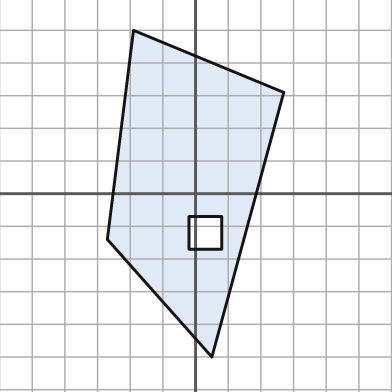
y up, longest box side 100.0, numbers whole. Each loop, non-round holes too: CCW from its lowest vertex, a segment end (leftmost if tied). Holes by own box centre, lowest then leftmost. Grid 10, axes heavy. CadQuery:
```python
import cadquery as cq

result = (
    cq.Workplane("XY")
    .moveTo(5.0, -50.0)
    .lineTo(27.0, 31.0)
    .lineTo(-19.0, 50.0)
    .lineTo(-27.0, -14.0)
    .close()
    .moveTo(-2.0, -17.0)
    .lineTo(8.0, -17.0)
    .lineTo(8.0, -7.0)
    .lineTo(-2.0, -7.0)
    .close()
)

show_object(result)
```